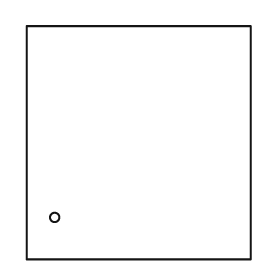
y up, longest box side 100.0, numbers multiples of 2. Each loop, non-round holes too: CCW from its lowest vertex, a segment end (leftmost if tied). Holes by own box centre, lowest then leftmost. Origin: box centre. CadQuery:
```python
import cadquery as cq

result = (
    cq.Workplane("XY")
    .moveTo(-48.0, -50.0)
    .lineTo(48.0, -50.0)
    .lineTo(48.0, 50.0)
    .lineTo(-48.0, 50.0)
    .close()
    .moveTo(-36.0, -32.0)
    .circle(2.0)
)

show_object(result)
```